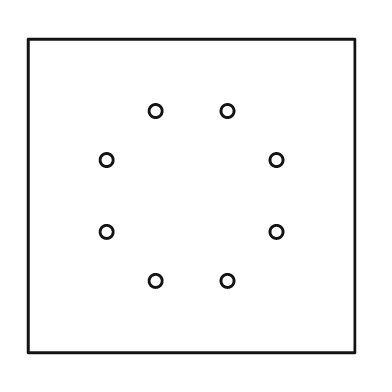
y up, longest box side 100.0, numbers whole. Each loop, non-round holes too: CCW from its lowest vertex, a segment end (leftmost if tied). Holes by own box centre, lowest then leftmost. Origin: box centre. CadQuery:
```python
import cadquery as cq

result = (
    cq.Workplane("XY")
    .moveTo(-50.0, -48.0)
    .lineTo(50.0, -48.0)
    .lineTo(50.0, 48.0)
    .lineTo(-50.0, 48.0)
    .close()
    .moveTo(-11.0, -26.0)
    .circle(2.0)
    .moveTo(11.0, -26.0)
    .circle(2.0)
    .moveTo(-26.0, -11.0)
    .circle(2.0)
    .moveTo(26.0, -11.0)
    .circle(2.0)
    .moveTo(-26.0, 11.0)
    .circle(2.0)
    .moveTo(26.0, 11.0)
    .circle(2.0)
    .moveTo(-11.0, 26.0)
    .circle(2.0)
    .moveTo(11.0, 26.0)
    .circle(2.0)
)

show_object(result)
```